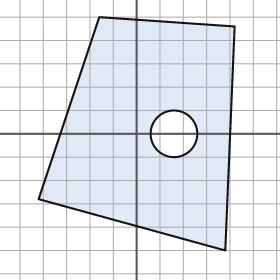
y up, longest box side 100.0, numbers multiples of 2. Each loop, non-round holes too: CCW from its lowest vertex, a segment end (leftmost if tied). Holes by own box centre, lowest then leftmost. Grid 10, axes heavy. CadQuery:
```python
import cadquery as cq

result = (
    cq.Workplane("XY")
    .moveTo(38.0, -50.0)
    .lineTo(42.0, 46.0)
    .lineTo(-16.0, 50.0)
    .lineTo(-42.0, -28.0)
    .close()
    .moveTo(16.0, 0.0)
    .circle(10.0)
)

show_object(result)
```